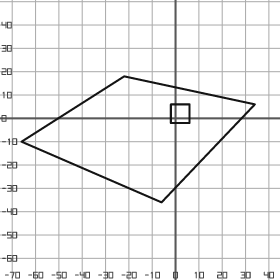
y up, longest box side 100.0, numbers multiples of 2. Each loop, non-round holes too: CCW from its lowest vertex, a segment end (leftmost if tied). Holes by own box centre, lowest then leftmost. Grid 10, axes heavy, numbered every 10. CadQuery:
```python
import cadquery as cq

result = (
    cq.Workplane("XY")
    .moveTo(-6.0, -36.0)
    .lineTo(34.0, 6.0)
    .lineTo(-22.0, 18.0)
    .lineTo(-66.0, -10.0)
    .close()
    .moveTo(-2.0, -2.0)
    .lineTo(6.0, -2.0)
    .lineTo(6.0, 6.0)
    .lineTo(-2.0, 6.0)
    .close()
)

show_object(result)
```